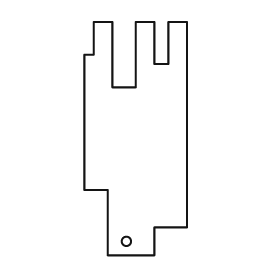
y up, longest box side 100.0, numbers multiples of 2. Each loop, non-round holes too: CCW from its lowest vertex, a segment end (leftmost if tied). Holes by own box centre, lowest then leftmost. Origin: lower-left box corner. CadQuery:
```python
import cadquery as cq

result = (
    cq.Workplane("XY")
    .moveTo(10.0, 0.0)
    .lineTo(30.0, 0.0)
    .lineTo(30.0, 12.0)
    .lineTo(44.0, 12.0)
    .lineTo(44.0, 100.0)
    .lineTo(36.0, 100.0)
    .lineTo(36.0, 82.0)
    .lineTo(30.0, 82.0)
    .lineTo(30.0, 100.0)
    .lineTo(22.0, 100.0)
    .lineTo(22.0, 72.0)
    .lineTo(12.0, 72.0)
    .lineTo(12.0, 100.0)
    .lineTo(4.0, 100.0)
    .lineTo(4.0, 86.0)
    .lineTo(0.0, 86.0)
    .lineTo(0.0, 28.0)
    .lineTo(10.0, 28.0)
    .close()
    .moveTo(18.0, 6.0)
    .circle(2.0)
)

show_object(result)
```